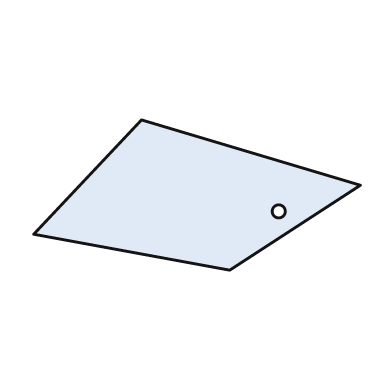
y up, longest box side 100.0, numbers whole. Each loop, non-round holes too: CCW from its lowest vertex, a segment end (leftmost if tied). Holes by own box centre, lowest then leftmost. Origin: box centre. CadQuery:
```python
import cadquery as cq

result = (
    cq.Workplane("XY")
    .moveTo(10.0, -23.0)
    .lineTo(50.0, 3.0)
    .lineTo(-17.0, 23.0)
    .lineTo(-50.0, -12.0)
    .close()
    .moveTo(25.0, -5.0)
    .circle(2.0)
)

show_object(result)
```